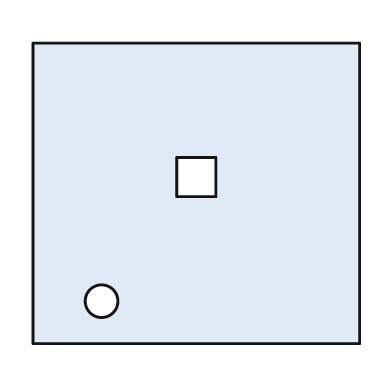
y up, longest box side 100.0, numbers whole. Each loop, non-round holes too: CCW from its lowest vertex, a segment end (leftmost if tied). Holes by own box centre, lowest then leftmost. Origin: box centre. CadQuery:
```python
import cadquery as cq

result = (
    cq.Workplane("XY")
    .moveTo(-50.0, -46.0)
    .lineTo(50.0, -46.0)
    .lineTo(50.0, 46.0)
    .lineTo(-50.0, 46.0)
    .close()
    .moveTo(-29.0, -33.0)
    .circle(5.0)
    .moveTo(-6.0, -1.0)
    .lineTo(6.0, -1.0)
    .lineTo(6.0, 11.0)
    .lineTo(-6.0, 11.0)
    .close()
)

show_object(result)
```